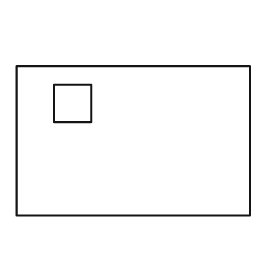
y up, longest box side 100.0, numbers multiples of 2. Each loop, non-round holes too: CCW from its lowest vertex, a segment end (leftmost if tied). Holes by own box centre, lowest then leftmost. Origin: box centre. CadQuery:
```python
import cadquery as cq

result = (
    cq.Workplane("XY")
    .moveTo(-50.0, -32.0)
    .lineTo(50.0, -32.0)
    .lineTo(50.0, 32.0)
    .lineTo(-50.0, 32.0)
    .close()
    .moveTo(-34.0, 8.0)
    .lineTo(-18.0, 8.0)
    .lineTo(-18.0, 24.0)
    .lineTo(-34.0, 24.0)
    .close()
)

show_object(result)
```